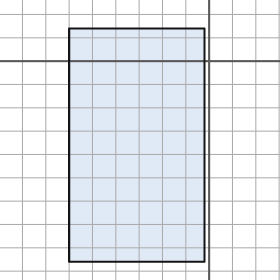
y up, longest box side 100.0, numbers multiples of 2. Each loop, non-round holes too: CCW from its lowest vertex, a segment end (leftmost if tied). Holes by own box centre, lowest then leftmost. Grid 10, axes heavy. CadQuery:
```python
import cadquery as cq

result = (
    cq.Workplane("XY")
    .moveTo(-60.0, -86.0)
    .lineTo(-2.0, -86.0)
    .lineTo(-2.0, 14.0)
    .lineTo(-60.0, 14.0)
    .close()
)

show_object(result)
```